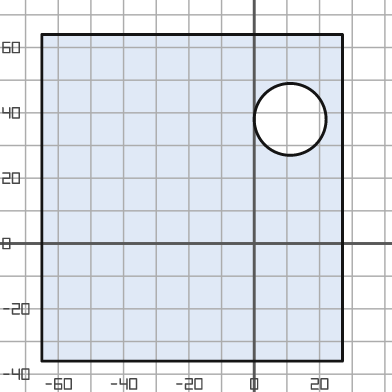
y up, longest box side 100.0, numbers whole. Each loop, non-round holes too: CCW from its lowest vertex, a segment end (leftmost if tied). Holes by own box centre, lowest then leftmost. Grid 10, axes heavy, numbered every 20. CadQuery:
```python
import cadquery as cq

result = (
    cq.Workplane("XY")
    .moveTo(-65.0, -36.0)
    .lineTo(27.0, -36.0)
    .lineTo(27.0, 64.0)
    .lineTo(-65.0, 64.0)
    .close()
    .moveTo(11.0, 38.0)
    .circle(11.0)
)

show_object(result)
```